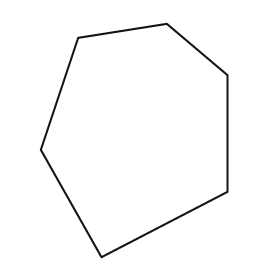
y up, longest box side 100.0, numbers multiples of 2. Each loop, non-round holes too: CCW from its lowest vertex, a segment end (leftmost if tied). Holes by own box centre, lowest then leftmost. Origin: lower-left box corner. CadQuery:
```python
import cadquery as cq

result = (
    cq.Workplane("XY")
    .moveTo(26.0, 0.0)
    .lineTo(80.0, 28.0)
    .lineTo(80.0, 78.0)
    .lineTo(54.0, 100.0)
    .lineTo(16.0, 94.0)
    .lineTo(0.0, 46.0)
    .close()
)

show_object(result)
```